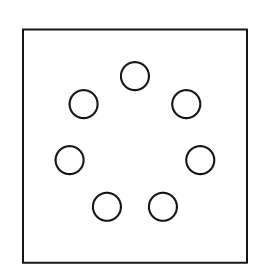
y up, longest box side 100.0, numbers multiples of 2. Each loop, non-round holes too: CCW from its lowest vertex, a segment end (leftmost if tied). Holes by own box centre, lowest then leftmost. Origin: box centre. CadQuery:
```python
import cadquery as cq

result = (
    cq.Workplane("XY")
    .moveTo(-48.0, -50.0)
    .lineTo(48.0, -50.0)
    .lineTo(48.0, 50.0)
    .lineTo(-48.0, 50.0)
    .close()
    .moveTo(-12.0, -26.0)
    .circle(6.0)
    .moveTo(12.0, -26.0)
    .circle(6.0)
    .moveTo(-28.0, -6.0)
    .circle(6.0)
    .moveTo(28.0, -6.0)
    .circle(6.0)
    .moveTo(-22.0, 18.0)
    .circle(6.0)
    .moveTo(22.0, 18.0)
    .circle(6.0)
    .moveTo(0.0, 30.0)
    .circle(6.0)
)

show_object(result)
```